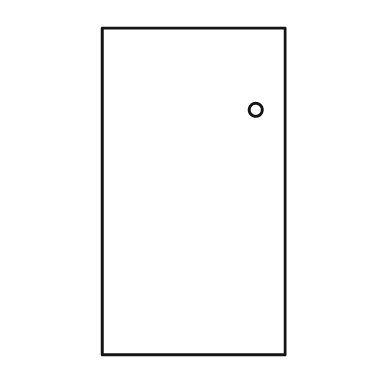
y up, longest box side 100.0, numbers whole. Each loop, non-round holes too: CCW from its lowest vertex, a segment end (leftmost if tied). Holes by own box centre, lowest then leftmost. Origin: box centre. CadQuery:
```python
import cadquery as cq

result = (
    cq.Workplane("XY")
    .moveTo(-28.0, -50.0)
    .lineTo(28.0, -50.0)
    .lineTo(28.0, 50.0)
    .lineTo(-28.0, 50.0)
    .close()
    .moveTo(19.0, 25.0)
    .circle(2.0)
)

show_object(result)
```